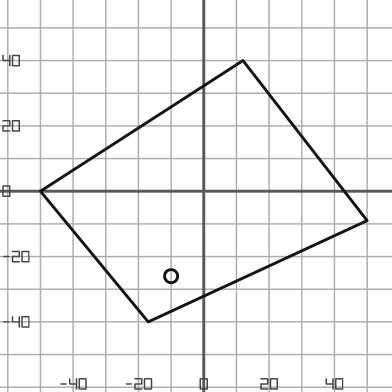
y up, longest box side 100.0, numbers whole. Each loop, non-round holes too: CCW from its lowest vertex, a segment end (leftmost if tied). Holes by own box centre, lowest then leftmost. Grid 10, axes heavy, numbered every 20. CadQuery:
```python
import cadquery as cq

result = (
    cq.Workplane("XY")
    .moveTo(-17.0, -40.0)
    .lineTo(50.0, -9.0)
    .lineTo(12.0, 40.0)
    .lineTo(-50.0, 0.0)
    .close()
    .moveTo(-10.0, -26.0)
    .circle(2.0)
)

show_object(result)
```